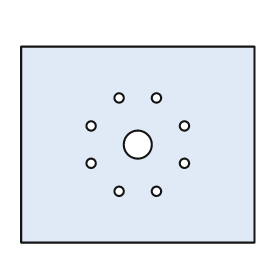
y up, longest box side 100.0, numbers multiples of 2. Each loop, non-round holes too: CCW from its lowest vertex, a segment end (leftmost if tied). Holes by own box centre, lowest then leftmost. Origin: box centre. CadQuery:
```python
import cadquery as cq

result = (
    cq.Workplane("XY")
    .moveTo(-50.0, -42.0)
    .lineTo(50.0, -42.0)
    .lineTo(50.0, 42.0)
    .lineTo(-50.0, 42.0)
    .close()
    .moveTo(-8.0, -20.0)
    .circle(2.0)
    .moveTo(8.0, -20.0)
    .circle(2.0)
    .moveTo(-20.0, -8.0)
    .circle(2.0)
    .moveTo(20.0, -8.0)
    .circle(2.0)
    .moveTo(0.0, 0.0)
    .circle(6.0)
    .moveTo(-20.0, 8.0)
    .circle(2.0)
    .moveTo(20.0, 8.0)
    .circle(2.0)
    .moveTo(-8.0, 20.0)
    .circle(2.0)
    .moveTo(8.0, 20.0)
    .circle(2.0)
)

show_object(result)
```